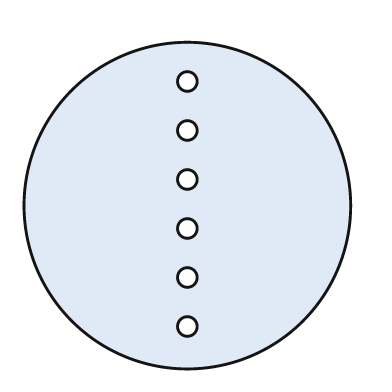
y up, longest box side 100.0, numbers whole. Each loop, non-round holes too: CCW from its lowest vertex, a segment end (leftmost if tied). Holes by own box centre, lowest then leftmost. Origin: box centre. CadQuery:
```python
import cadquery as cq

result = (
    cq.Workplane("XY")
    .moveTo(0.0, 0.0)
    .circle(50.0)
    .moveTo(0.0, -37.0)
    .circle(3.0)
    .moveTo(0.0, -22.0)
    .circle(3.0)
    .moveTo(0.0, -7.0)
    .circle(3.0)
    .moveTo(0.0, 8.0)
    .circle(3.0)
    .moveTo(0.0, 23.0)
    .circle(3.0)
    .moveTo(0.0, 38.0)
    .circle(3.0)
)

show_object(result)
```